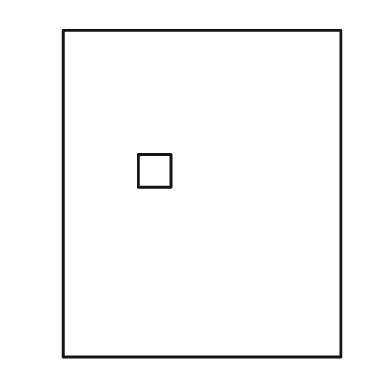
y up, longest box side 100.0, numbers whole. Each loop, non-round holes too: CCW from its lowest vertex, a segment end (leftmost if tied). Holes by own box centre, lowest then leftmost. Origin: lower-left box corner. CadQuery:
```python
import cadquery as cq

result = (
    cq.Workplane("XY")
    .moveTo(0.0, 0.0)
    .lineTo(85.0, 0.0)
    .lineTo(85.0, 100.0)
    .lineTo(0.0, 100.0)
    .close()
    .moveTo(23.0, 52.0)
    .lineTo(33.0, 52.0)
    .lineTo(33.0, 62.0)
    .lineTo(23.0, 62.0)
    .close()
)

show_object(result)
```